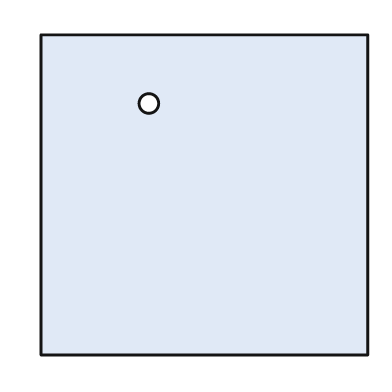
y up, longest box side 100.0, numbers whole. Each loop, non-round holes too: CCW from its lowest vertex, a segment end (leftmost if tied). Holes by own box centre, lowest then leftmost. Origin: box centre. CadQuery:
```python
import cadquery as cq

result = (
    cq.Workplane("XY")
    .moveTo(-50.0, -49.0)
    .lineTo(50.0, -49.0)
    .lineTo(50.0, 49.0)
    .lineTo(-50.0, 49.0)
    .close()
    .moveTo(-17.0, 28.0)
    .circle(3.0)
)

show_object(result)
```